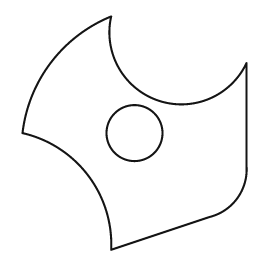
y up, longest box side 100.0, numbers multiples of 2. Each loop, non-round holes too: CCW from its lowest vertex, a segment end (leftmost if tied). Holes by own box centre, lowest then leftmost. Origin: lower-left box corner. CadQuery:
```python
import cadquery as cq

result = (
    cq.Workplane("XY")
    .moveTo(38.0, 0.0)
    .lineTo(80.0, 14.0)
    .threePointArc((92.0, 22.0), (96.0, 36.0))
    .lineTo(96.0, 80.0)
    .threePointArc((58.0, 64.0), (38.0, 100.0))
    .threePointArc((12.0, 80.0), (0.0, 50.0))
    .threePointArc((28.0, 32.0), (38.0, 0.0))
    .close()
    .moveTo(48.0, 50.0)
    .circle(12.0)
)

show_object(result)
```